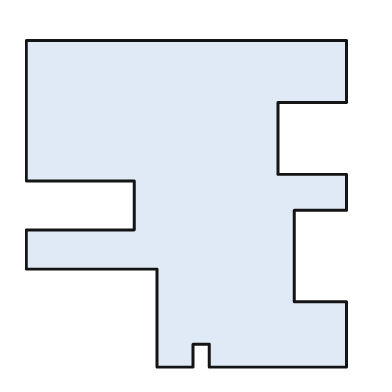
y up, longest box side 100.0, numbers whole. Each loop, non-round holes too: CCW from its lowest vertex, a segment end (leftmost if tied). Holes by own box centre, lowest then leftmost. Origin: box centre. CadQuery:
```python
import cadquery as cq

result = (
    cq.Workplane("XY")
    .moveTo(-9.0, -50.0)
    .lineTo(2.0, -50.0)
    .lineTo(2.0, -43.0)
    .lineTo(7.0, -43.0)
    .lineTo(7.0, -50.0)
    .lineTo(49.0, -50.0)
    .lineTo(49.0, -30.0)
    .lineTo(33.0, -30.0)
    .lineTo(33.0, -2.0)
    .lineTo(49.0, -2.0)
    .lineTo(49.0, 9.0)
    .lineTo(28.0, 9.0)
    .lineTo(28.0, 31.0)
    .lineTo(49.0, 31.0)
    .lineTo(49.0, 50.0)
    .lineTo(-49.0, 50.0)
    .lineTo(-49.0, 7.0)
    .lineTo(-16.0, 7.0)
    .lineTo(-16.0, -8.0)
    .lineTo(-49.0, -8.0)
    .lineTo(-49.0, -20.0)
    .lineTo(-9.0, -20.0)
    .close()
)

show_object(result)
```